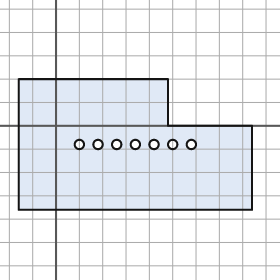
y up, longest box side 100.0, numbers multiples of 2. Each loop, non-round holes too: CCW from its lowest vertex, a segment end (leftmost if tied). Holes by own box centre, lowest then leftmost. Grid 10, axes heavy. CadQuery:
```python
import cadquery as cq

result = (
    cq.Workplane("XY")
    .moveTo(-16.0, -36.0)
    .lineTo(84.0, -36.0)
    .lineTo(84.0, 0.0)
    .lineTo(48.0, 0.0)
    .lineTo(48.0, 20.0)
    .lineTo(-16.0, 20.0)
    .close()
    .moveTo(10.0, -8.0)
    .circle(2.0)
    .moveTo(18.0, -8.0)
    .circle(2.0)
    .moveTo(26.0, -8.0)
    .circle(2.0)
    .moveTo(34.0, -8.0)
    .circle(2.0)
    .moveTo(42.0, -8.0)
    .circle(2.0)
    .moveTo(50.0, -8.0)
    .circle(2.0)
    .moveTo(58.0, -8.0)
    .circle(2.0)
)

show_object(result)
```